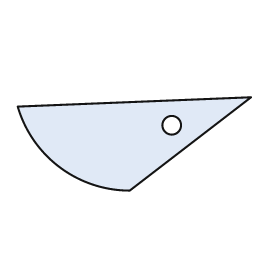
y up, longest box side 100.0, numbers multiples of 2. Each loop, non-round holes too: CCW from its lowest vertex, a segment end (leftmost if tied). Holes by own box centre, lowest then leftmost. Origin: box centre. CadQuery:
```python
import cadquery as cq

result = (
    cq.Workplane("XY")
    .moveTo(-2.0, -20.0)
    .lineTo(50.0, 20.0)
    .lineTo(-50.0, 16.0)
    .threePointArc((-32.0, -10.0), (-2.0, -20.0))
    .close()
    .moveTo(16.0, 8.0)
    .circle(4.0)
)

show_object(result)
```